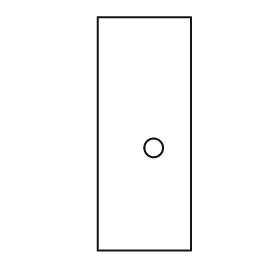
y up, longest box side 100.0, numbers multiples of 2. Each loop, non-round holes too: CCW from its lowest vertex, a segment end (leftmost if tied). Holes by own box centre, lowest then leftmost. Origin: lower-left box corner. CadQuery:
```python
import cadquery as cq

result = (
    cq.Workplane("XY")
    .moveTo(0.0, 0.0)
    .lineTo(40.0, 0.0)
    .lineTo(40.0, 100.0)
    .lineTo(0.0, 100.0)
    .close()
    .moveTo(24.0, 44.0)
    .circle(4.0)
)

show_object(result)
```